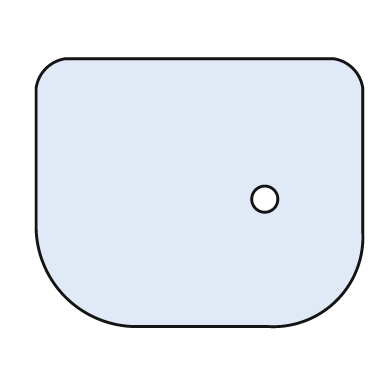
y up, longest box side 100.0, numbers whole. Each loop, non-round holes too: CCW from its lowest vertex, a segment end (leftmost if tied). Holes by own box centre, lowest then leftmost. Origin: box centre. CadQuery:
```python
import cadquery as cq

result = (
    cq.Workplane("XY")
    .moveTo(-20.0, -41.0)
    .lineTo(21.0, -41.0)
    .threePointArc((42.0, -33.0), (50.0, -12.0))
    .lineTo(50.0, 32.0)
    .threePointArc((47.0, 38.0), (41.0, 41.0))
    .lineTo(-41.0, 41.0)
    .threePointArc((-47.0, 38.0), (-50.0, 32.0))
    .lineTo(-50.0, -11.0)
    .threePointArc((-41.0, -32.0), (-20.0, -41.0))
    .close()
    .moveTo(20.0, -2.0)
    .circle(4.0)
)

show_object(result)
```